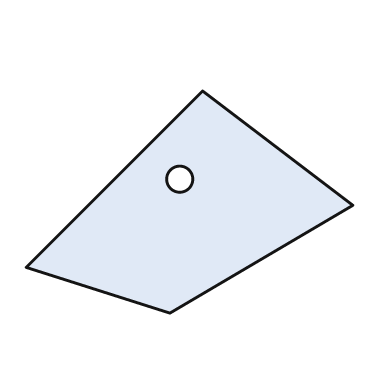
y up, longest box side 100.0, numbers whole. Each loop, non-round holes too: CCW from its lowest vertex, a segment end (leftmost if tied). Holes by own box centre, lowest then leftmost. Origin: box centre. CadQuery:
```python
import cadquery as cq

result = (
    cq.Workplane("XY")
    .moveTo(-6.0, -34.0)
    .lineTo(50.0, -1.0)
    .lineTo(4.0, 34.0)
    .lineTo(-50.0, -20.0)
    .close()
    .moveTo(-3.0, 7.0)
    .circle(4.0)
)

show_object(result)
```